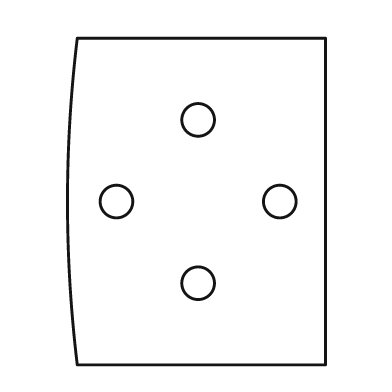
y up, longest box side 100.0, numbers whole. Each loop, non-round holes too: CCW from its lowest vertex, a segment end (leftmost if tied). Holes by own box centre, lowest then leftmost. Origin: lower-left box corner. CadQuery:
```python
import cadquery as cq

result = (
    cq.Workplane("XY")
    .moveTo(3.0, 0.0)
    .lineTo(79.0, 0.0)
    .lineTo(79.0, 100.0)
    .lineTo(3.0, 100.0)
    .threePointArc((0.0, 50.0), (3.0, 0.0))
    .close()
    .moveTo(40.0, 25.0)
    .circle(5.0)
    .moveTo(15.0, 50.0)
    .circle(5.0)
    .moveTo(65.0, 50.0)
    .circle(5.0)
    .moveTo(40.0, 75.0)
    .circle(5.0)
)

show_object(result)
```